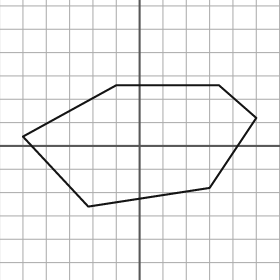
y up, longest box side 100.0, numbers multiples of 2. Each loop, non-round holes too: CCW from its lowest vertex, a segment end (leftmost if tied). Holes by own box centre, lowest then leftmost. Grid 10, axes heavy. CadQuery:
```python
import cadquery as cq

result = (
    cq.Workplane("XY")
    .moveTo(-22.0, -26.0)
    .lineTo(30.0, -18.0)
    .lineTo(50.0, 12.0)
    .lineTo(34.0, 26.0)
    .lineTo(-10.0, 26.0)
    .lineTo(-50.0, 4.0)
    .close()
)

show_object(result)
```